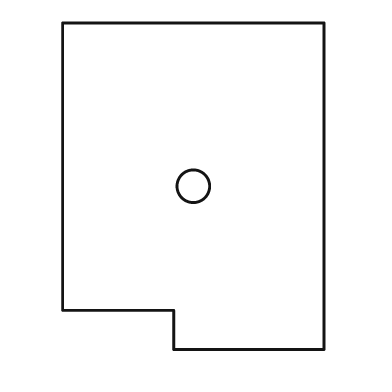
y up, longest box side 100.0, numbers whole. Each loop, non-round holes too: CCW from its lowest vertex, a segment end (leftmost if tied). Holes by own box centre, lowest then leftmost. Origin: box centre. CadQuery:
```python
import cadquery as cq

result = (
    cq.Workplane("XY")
    .moveTo(-6.0, -50.0)
    .lineTo(40.0, -50.0)
    .lineTo(40.0, 50.0)
    .lineTo(-40.0, 50.0)
    .lineTo(-40.0, -38.0)
    .lineTo(-6.0, -38.0)
    .close()
    .moveTo(0.0, 0.0)
    .circle(5.0)
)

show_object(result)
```